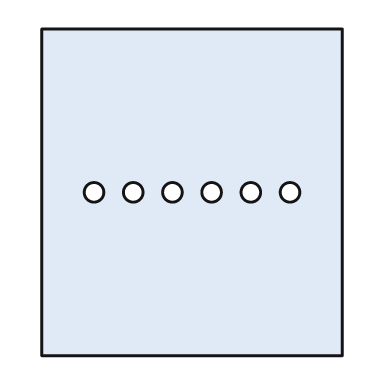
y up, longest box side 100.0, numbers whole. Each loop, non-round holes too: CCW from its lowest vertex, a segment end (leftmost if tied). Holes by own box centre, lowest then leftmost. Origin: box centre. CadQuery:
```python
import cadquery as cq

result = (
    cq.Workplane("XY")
    .moveTo(-46.0, -50.0)
    .lineTo(46.0, -50.0)
    .lineTo(46.0, 50.0)
    .lineTo(-46.0, 50.0)
    .close()
    .moveTo(-30.0, 0.0)
    .circle(3.0)
    .moveTo(-18.0, 0.0)
    .circle(3.0)
    .moveTo(-6.0, 0.0)
    .circle(3.0)
    .moveTo(6.0, 0.0)
    .circle(3.0)
    .moveTo(18.0, 0.0)
    .circle(3.0)
    .moveTo(30.0, 0.0)
    .circle(3.0)
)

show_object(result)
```